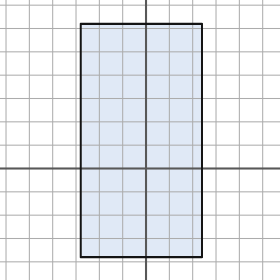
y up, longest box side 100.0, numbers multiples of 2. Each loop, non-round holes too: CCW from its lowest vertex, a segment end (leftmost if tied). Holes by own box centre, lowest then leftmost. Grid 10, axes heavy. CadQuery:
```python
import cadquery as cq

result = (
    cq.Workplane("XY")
    .moveTo(-28.0, -38.0)
    .lineTo(24.0, -38.0)
    .lineTo(24.0, 62.0)
    .lineTo(-28.0, 62.0)
    .close()
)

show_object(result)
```